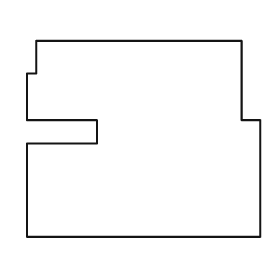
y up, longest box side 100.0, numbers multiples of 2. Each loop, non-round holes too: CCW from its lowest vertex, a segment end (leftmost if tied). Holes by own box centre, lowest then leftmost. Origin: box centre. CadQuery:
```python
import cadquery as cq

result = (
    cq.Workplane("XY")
    .moveTo(-50.0, -42.0)
    .lineTo(50.0, -42.0)
    .lineTo(50.0, 8.0)
    .lineTo(42.0, 8.0)
    .lineTo(42.0, 42.0)
    .lineTo(-46.0, 42.0)
    .lineTo(-46.0, 28.0)
    .lineTo(-50.0, 28.0)
    .lineTo(-50.0, 8.0)
    .lineTo(-20.0, 8.0)
    .lineTo(-20.0, -2.0)
    .lineTo(-50.0, -2.0)
    .close()
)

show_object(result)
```